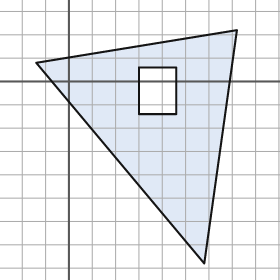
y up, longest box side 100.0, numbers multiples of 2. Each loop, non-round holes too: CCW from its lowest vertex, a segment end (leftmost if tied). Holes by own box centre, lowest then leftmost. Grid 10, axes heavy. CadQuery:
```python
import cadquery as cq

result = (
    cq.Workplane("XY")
    .moveTo(58.0, -78.0)
    .lineTo(72.0, 22.0)
    .lineTo(-14.0, 8.0)
    .close()
    .moveTo(30.0, -14.0)
    .lineTo(46.0, -14.0)
    .lineTo(46.0, 6.0)
    .lineTo(30.0, 6.0)
    .close()
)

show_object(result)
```